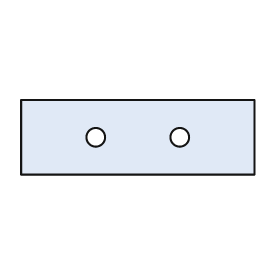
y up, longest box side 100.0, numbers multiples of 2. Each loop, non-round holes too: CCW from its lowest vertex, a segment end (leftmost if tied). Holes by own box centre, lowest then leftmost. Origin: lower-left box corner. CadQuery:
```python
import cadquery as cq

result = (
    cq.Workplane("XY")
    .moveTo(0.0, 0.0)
    .lineTo(100.0, 0.0)
    .lineTo(100.0, 32.0)
    .lineTo(0.0, 32.0)
    .close()
    .moveTo(32.0, 16.0)
    .circle(4.0)
    .moveTo(68.0, 16.0)
    .circle(4.0)
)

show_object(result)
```